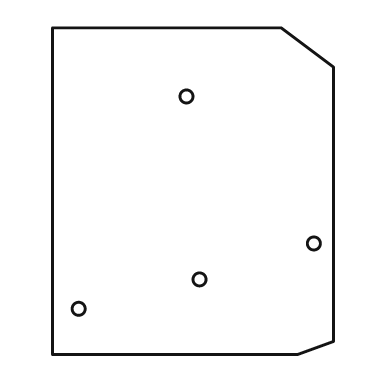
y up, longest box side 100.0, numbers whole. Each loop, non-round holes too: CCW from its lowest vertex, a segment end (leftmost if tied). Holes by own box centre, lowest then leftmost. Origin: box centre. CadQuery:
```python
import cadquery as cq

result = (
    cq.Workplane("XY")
    .moveTo(-43.0, -50.0)
    .lineTo(32.0, -50.0)
    .lineTo(43.0, -46.0)
    .lineTo(43.0, 38.0)
    .lineTo(27.0, 50.0)
    .lineTo(-43.0, 50.0)
    .close()
    .moveTo(-35.0, -36.0)
    .circle(2.0)
    .moveTo(2.0, -27.0)
    .circle(2.0)
    .moveTo(37.0, -16.0)
    .circle(2.0)
    .moveTo(-2.0, 29.0)
    .circle(2.0)
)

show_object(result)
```